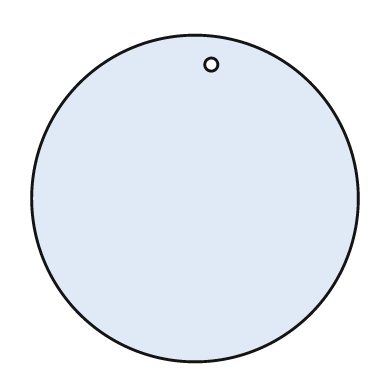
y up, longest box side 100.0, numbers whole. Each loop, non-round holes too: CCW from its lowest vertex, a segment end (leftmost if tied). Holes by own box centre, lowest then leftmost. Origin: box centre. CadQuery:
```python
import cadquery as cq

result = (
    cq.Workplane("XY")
    .moveTo(0.0, 0.0)
    .circle(50.0)
    .moveTo(5.0, 41.0)
    .circle(2.0)
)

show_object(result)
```